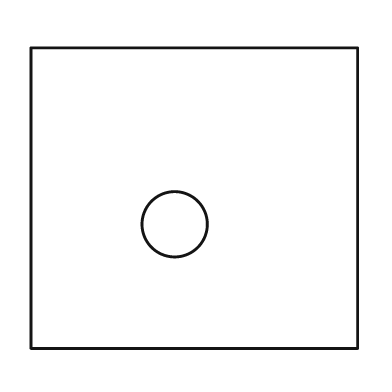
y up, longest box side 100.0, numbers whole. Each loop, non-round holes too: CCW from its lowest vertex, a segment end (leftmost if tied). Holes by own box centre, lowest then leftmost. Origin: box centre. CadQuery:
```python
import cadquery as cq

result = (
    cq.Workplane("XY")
    .moveTo(-50.0, -46.0)
    .lineTo(50.0, -46.0)
    .lineTo(50.0, 46.0)
    .lineTo(-50.0, 46.0)
    .close()
    .moveTo(-6.0, -8.0)
    .circle(10.0)
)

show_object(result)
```